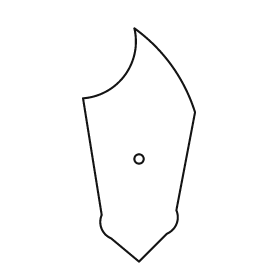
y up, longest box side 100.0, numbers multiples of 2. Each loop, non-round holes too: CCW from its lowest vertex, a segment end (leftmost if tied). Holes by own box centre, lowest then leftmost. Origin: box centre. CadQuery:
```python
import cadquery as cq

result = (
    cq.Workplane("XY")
    .moveTo(0.0, -50.0)
    .lineTo(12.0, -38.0)
    .threePointArc((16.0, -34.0), (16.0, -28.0))
    .lineTo(24.0, 14.0)
    .threePointArc((14.0, 34.0), (-2.0, 50.0))
    .threePointArc((-6.0, 30.0), (-24.0, 20.0))
    .lineTo(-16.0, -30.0)
    .threePointArc((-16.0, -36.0), (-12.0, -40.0))
    .close()
    .moveTo(0.0, -6.0)
    .circle(2.0)
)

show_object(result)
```